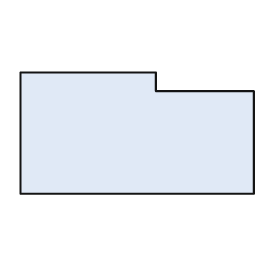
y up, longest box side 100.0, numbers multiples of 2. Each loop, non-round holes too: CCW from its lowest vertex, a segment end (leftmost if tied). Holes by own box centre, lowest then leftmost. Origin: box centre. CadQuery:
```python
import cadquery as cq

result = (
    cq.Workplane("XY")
    .moveTo(-50.0, -26.0)
    .lineTo(50.0, -26.0)
    .lineTo(50.0, 18.0)
    .lineTo(8.0, 18.0)
    .lineTo(8.0, 26.0)
    .lineTo(-50.0, 26.0)
    .close()
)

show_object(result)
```